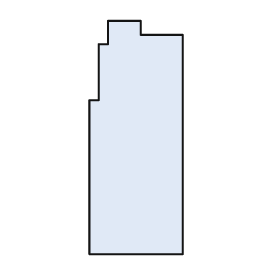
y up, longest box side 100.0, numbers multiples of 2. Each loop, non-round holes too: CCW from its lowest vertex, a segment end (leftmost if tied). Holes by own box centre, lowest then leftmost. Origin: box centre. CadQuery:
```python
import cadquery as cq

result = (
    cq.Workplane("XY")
    .moveTo(-20.0, -50.0)
    .lineTo(20.0, -50.0)
    .lineTo(20.0, 44.0)
    .lineTo(2.0, 44.0)
    .lineTo(2.0, 50.0)
    .lineTo(-12.0, 50.0)
    .lineTo(-12.0, 40.0)
    .lineTo(-16.0, 40.0)
    .lineTo(-16.0, 16.0)
    .lineTo(-20.0, 16.0)
    .close()
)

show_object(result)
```